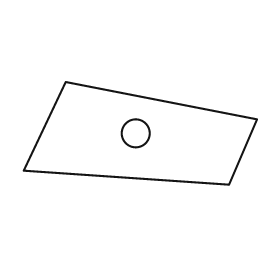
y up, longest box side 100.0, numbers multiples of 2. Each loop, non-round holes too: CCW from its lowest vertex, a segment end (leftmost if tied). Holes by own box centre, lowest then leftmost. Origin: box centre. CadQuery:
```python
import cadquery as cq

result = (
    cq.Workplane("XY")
    .moveTo(38.0, -22.0)
    .lineTo(50.0, 6.0)
    .lineTo(-32.0, 22.0)
    .lineTo(-50.0, -16.0)
    .close()
    .moveTo(-2.0, 0.0)
    .circle(6.0)
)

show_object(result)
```